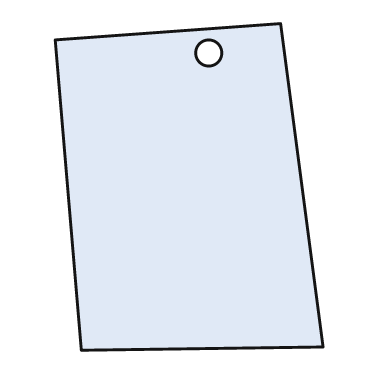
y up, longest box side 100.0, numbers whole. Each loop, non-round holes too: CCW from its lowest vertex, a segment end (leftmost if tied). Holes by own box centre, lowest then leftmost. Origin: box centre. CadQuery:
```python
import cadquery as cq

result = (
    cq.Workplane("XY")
    .moveTo(-33.0, -50.0)
    .lineTo(41.0, -49.0)
    .lineTo(28.0, 50.0)
    .lineTo(-41.0, 45.0)
    .close()
    .moveTo(6.0, 41.0)
    .circle(4.0)
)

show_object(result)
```